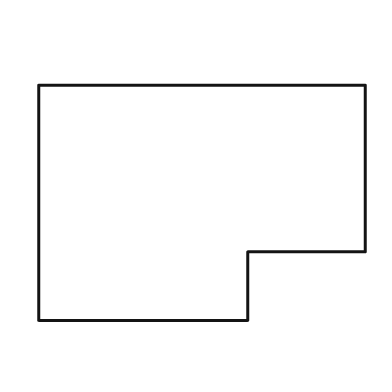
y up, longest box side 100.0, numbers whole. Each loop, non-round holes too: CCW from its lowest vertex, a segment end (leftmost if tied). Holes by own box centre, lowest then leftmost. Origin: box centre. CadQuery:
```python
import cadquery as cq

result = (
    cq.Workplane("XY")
    .moveTo(-50.0, -36.0)
    .lineTo(14.0, -36.0)
    .lineTo(14.0, -15.0)
    .lineTo(50.0, -15.0)
    .lineTo(50.0, 36.0)
    .lineTo(-50.0, 36.0)
    .close()
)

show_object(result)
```